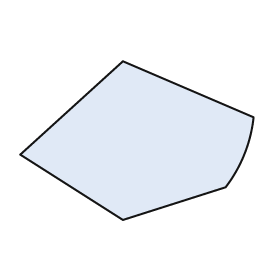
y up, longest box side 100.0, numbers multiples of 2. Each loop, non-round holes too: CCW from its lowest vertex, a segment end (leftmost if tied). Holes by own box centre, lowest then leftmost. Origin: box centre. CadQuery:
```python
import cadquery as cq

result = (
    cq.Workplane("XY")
    .moveTo(-6.0, -34.0)
    .lineTo(38.0, -20.0)
    .threePointArc((46.0, -6.0), (50.0, 10.0))
    .lineTo(-6.0, 34.0)
    .lineTo(-50.0, -6.0)
    .close()
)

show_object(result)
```